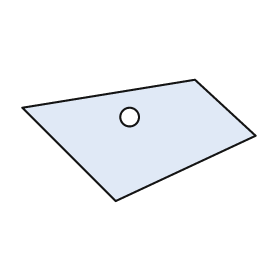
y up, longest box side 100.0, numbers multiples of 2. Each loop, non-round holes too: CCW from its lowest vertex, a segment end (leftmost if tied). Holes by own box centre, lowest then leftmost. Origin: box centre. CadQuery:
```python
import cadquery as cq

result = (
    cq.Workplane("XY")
    .moveTo(-10.0, -26.0)
    .lineTo(50.0, 2.0)
    .lineTo(24.0, 26.0)
    .lineTo(-50.0, 14.0)
    .close()
    .moveTo(-4.0, 10.0)
    .circle(4.0)
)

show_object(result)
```